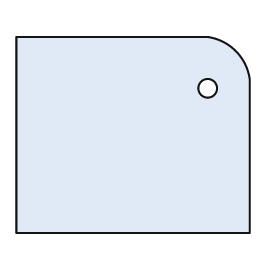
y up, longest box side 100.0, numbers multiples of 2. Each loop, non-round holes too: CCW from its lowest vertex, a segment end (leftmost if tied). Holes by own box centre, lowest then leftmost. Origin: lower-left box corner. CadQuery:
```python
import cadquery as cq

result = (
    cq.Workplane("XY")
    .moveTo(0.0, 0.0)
    .lineTo(100.0, 0.0)
    .lineTo(100.0, 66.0)
    .threePointArc((94.0, 78.0), (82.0, 84.0))
    .lineTo(0.0, 84.0)
    .close()
    .moveTo(82.0, 62.0)
    .circle(4.0)
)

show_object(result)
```